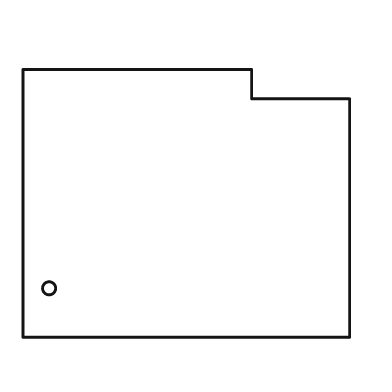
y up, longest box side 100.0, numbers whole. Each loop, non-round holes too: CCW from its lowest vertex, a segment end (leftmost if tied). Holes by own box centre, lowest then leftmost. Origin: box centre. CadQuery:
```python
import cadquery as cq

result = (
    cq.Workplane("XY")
    .moveTo(-50.0, -41.0)
    .lineTo(50.0, -41.0)
    .lineTo(50.0, 32.0)
    .lineTo(20.0, 32.0)
    .lineTo(20.0, 41.0)
    .lineTo(-50.0, 41.0)
    .close()
    .moveTo(-42.0, -26.0)
    .circle(2.0)
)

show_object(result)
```